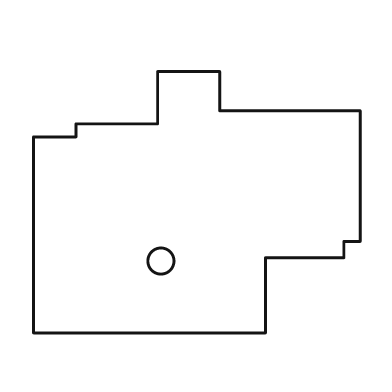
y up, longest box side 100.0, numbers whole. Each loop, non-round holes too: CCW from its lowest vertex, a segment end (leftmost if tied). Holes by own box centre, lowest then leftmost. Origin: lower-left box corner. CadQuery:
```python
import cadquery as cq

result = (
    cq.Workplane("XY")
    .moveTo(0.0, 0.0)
    .lineTo(71.0, 0.0)
    .lineTo(71.0, 23.0)
    .lineTo(95.0, 23.0)
    .lineTo(95.0, 28.0)
    .lineTo(100.0, 28.0)
    .lineTo(100.0, 68.0)
    .lineTo(57.0, 68.0)
    .lineTo(57.0, 80.0)
    .lineTo(38.0, 80.0)
    .lineTo(38.0, 64.0)
    .lineTo(13.0, 64.0)
    .lineTo(13.0, 60.0)
    .lineTo(0.0, 60.0)
    .close()
    .moveTo(39.0, 22.0)
    .circle(4.0)
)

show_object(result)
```